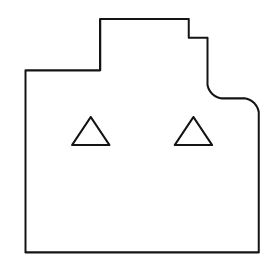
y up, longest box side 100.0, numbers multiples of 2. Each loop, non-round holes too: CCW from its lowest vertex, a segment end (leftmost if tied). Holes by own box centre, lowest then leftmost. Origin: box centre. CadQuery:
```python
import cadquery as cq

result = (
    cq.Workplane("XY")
    .moveTo(-50.0, -50.0)
    .lineTo(50.0, -50.0)
    .lineTo(50.0, 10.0)
    .threePointArc((48.0, 14.0), (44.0, 16.0))
    .lineTo(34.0, 16.0)
    .threePointArc((30.0, 18.0), (28.0, 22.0))
    .lineTo(28.0, 42.0)
    .lineTo(20.0, 42.0)
    .lineTo(20.0, 50.0)
    .lineTo(-18.0, 50.0)
    .lineTo(-18.0, 28.0)
    .lineTo(-50.0, 28.0)
    .close()
    .moveTo(-30.0, -4.0)
    .lineTo(-14.0, -4.0)
    .lineTo(-22.0, 8.0)
    .close()
    .moveTo(14.0, -4.0)
    .lineTo(30.0, -4.0)
    .lineTo(22.0, 8.0)
    .close()
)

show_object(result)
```